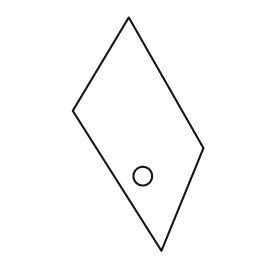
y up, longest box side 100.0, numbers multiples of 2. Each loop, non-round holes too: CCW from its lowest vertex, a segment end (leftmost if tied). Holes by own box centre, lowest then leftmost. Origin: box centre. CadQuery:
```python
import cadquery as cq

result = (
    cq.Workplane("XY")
    .moveTo(10.0, -50.0)
    .lineTo(28.0, -6.0)
    .lineTo(-4.0, 50.0)
    .lineTo(-28.0, 10.0)
    .close()
    .moveTo(2.0, -18.0)
    .circle(4.0)
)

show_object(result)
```